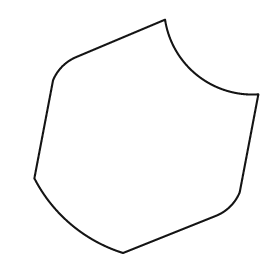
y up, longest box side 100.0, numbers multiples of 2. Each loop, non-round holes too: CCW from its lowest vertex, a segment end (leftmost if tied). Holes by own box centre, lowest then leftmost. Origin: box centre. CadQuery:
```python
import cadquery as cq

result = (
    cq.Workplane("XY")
    .moveTo(-10.0, -50.0)
    .lineTo(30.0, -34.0)
    .threePointArc((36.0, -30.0), (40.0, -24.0))
    .lineTo(48.0, 18.0)
    .threePointArc((22.0, 26.0), (8.0, 50.0))
    .lineTo(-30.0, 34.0)
    .threePointArc((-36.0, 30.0), (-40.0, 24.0))
    .lineTo(-48.0, -18.0)
    .threePointArc((-32.0, -38.0), (-10.0, -50.0))
    .close()
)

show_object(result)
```